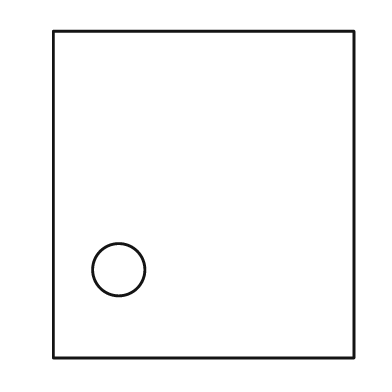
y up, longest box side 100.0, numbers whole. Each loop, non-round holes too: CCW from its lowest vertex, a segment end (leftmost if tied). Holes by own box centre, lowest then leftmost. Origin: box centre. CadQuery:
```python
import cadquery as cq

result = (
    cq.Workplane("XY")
    .moveTo(-46.0, -50.0)
    .lineTo(46.0, -50.0)
    .lineTo(46.0, 50.0)
    .lineTo(-46.0, 50.0)
    .close()
    .moveTo(-26.0, -23.0)
    .circle(8.0)
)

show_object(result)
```